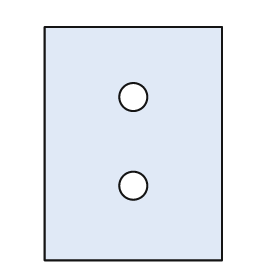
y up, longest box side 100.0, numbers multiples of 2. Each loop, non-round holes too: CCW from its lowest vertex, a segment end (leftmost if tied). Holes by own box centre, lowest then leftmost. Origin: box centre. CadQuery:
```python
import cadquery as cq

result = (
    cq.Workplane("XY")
    .moveTo(-38.0, -50.0)
    .lineTo(38.0, -50.0)
    .lineTo(38.0, 50.0)
    .lineTo(-38.0, 50.0)
    .close()
    .moveTo(0.0, -18.0)
    .circle(6.0)
    .moveTo(0.0, 20.0)
    .circle(6.0)
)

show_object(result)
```